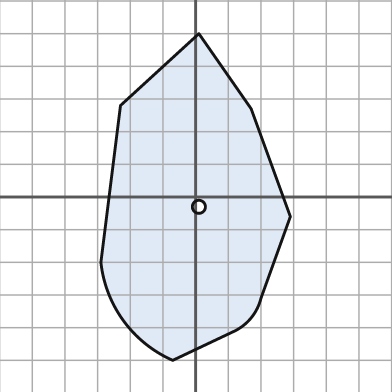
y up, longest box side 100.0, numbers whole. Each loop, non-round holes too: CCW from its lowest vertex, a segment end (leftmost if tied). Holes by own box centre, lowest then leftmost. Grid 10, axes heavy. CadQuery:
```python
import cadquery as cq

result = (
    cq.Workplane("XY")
    .moveTo(-7.0, -50.0)
    .lineTo(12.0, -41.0)
    .threePointArc((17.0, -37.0), (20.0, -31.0))
    .lineTo(29.0, -6.0)
    .lineTo(17.0, 27.0)
    .lineTo(1.0, 50.0)
    .lineTo(-23.0, 28.0)
    .lineTo(-29.0, -20.0)
    .threePointArc((-22.0, -38.0), (-7.0, -50.0))
    .close()
    .moveTo(1.0, -3.0)
    .circle(2.0)
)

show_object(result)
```